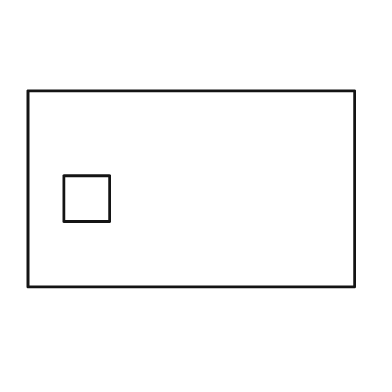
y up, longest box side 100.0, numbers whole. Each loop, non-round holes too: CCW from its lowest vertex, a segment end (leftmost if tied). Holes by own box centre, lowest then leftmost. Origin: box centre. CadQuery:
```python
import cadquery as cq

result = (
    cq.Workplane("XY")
    .moveTo(-50.0, -30.0)
    .lineTo(50.0, -30.0)
    .lineTo(50.0, 30.0)
    .lineTo(-50.0, 30.0)
    .close()
    .moveTo(-39.0, -10.0)
    .lineTo(-25.0, -10.0)
    .lineTo(-25.0, 4.0)
    .lineTo(-39.0, 4.0)
    .close()
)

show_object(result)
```